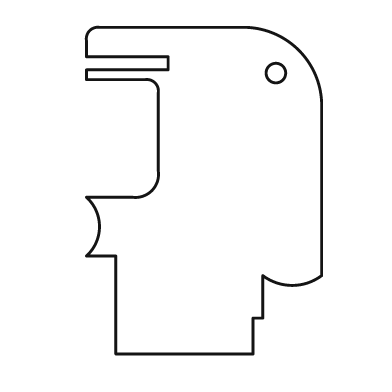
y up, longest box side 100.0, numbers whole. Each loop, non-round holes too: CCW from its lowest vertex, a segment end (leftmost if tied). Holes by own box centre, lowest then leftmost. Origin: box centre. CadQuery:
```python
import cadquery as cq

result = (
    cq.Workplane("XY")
    .moveTo(-27.0, -50.0)
    .lineTo(15.0, -50.0)
    .lineTo(15.0, -39.0)
    .lineTo(18.0, -39.0)
    .lineTo(18.0, -26.0)
    .threePointArc((27.0, -29.0), (36.0, -26.0))
    .lineTo(36.0, 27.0)
    .threePointArc((29.0, 43.0), (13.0, 50.0))
    .lineTo(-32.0, 50.0)
    .threePointArc((-35.0, 49.0), (-36.0, 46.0))
    .lineTo(-36.0, 41.0)
    .lineTo(-11.0, 41.0)
    .lineTo(-11.0, 37.0)
    .lineTo(-36.0, 37.0)
    .lineTo(-36.0, 34.0)
    .lineTo(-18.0, 34.0)
    .threePointArc((-15.0, 33.0), (-14.0, 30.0))
    .lineTo(-14.0, 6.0)
    .threePointArc((-16.0, 0.0), (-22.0, -2.0))
    .lineTo(-36.0, -2.0)
    .threePointArc((-32.0, -11.0), (-36.0, -20.0))
    .lineTo(-27.0, -20.0)
    .close()
    .moveTo(22.0, 36.0)
    .circle(3.0)
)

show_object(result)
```